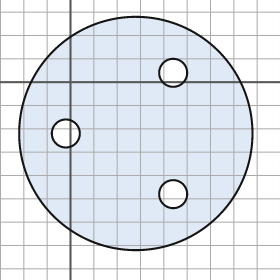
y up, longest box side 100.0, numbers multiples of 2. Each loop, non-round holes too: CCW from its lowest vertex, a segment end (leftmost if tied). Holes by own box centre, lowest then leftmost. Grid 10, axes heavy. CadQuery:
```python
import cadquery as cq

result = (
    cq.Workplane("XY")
    .moveTo(28.0, -22.0)
    .circle(50.0)
    .moveTo(44.0, -48.0)
    .circle(6.0)
    .moveTo(-2.0, -22.0)
    .circle(6.0)
    .moveTo(44.0, 4.0)
    .circle(6.0)
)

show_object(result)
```